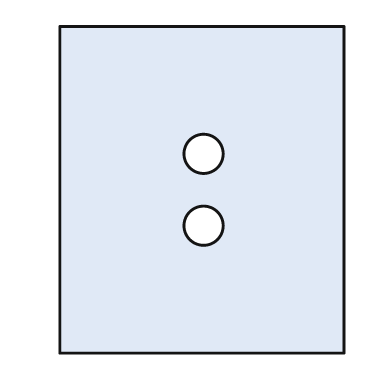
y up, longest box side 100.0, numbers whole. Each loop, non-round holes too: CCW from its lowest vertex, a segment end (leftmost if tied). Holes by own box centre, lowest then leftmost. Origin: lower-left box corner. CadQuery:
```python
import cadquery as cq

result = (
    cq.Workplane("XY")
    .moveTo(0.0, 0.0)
    .lineTo(87.0, 0.0)
    .lineTo(87.0, 100.0)
    .lineTo(0.0, 100.0)
    .close()
    .moveTo(44.0, 39.0)
    .circle(6.0)
    .moveTo(44.0, 61.0)
    .circle(6.0)
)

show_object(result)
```